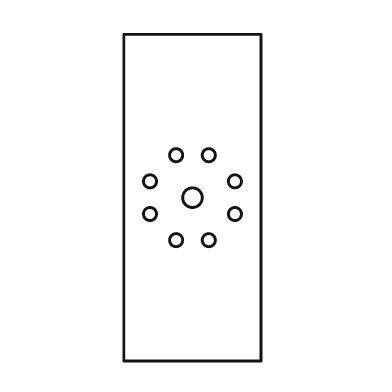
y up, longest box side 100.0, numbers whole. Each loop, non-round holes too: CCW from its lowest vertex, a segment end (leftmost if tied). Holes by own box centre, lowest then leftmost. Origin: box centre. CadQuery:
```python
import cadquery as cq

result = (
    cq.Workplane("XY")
    .moveTo(-21.0, -50.0)
    .lineTo(21.0, -50.0)
    .lineTo(21.0, 50.0)
    .lineTo(-21.0, 50.0)
    .close()
    .moveTo(-5.0, -13.0)
    .circle(2.0)
    .moveTo(5.0, -13.0)
    .circle(2.0)
    .moveTo(-13.0, -5.0)
    .circle(2.0)
    .moveTo(13.0, -5.0)
    .circle(2.0)
    .moveTo(0.0, 0.0)
    .circle(3.0)
    .moveTo(-13.0, 5.0)
    .circle(2.0)
    .moveTo(13.0, 5.0)
    .circle(2.0)
    .moveTo(-5.0, 13.0)
    .circle(2.0)
    .moveTo(5.0, 13.0)
    .circle(2.0)
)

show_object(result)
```